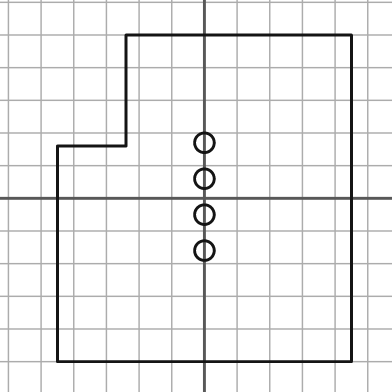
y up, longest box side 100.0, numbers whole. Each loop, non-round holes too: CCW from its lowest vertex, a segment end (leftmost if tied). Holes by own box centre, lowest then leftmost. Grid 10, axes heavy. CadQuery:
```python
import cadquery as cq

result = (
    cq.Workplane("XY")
    .moveTo(-45.0, -50.0)
    .lineTo(45.0, -50.0)
    .lineTo(45.0, 50.0)
    .lineTo(-24.0, 50.0)
    .lineTo(-24.0, 16.0)
    .lineTo(-45.0, 16.0)
    .close()
    .moveTo(0.0, -16.0)
    .circle(3.0)
    .moveTo(0.0, -5.0)
    .circle(3.0)
    .moveTo(0.0, 6.0)
    .circle(3.0)
    .moveTo(0.0, 17.0)
    .circle(3.0)
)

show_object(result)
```